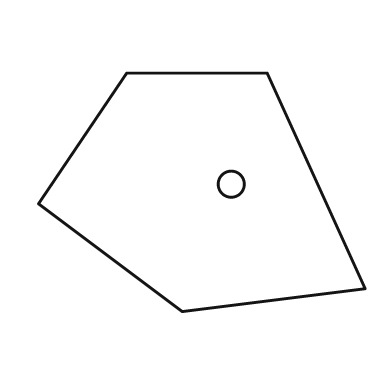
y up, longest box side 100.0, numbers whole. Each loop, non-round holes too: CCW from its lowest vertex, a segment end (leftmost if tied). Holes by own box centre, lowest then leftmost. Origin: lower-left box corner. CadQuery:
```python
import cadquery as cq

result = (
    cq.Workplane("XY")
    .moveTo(44.0, 0.0)
    .lineTo(100.0, 7.0)
    .lineTo(70.0, 73.0)
    .lineTo(27.0, 73.0)
    .lineTo(0.0, 33.0)
    .close()
    .moveTo(59.0, 39.0)
    .circle(4.0)
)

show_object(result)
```